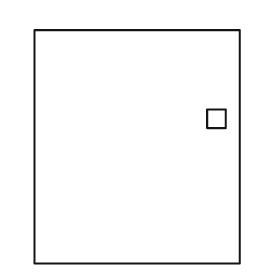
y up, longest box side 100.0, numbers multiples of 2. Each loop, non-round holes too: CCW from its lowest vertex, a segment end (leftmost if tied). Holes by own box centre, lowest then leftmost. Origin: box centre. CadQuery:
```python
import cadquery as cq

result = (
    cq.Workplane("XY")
    .moveTo(-44.0, -50.0)
    .lineTo(44.0, -50.0)
    .lineTo(44.0, 50.0)
    .lineTo(-44.0, 50.0)
    .close()
    .moveTo(30.0, 8.0)
    .lineTo(38.0, 8.0)
    .lineTo(38.0, 16.0)
    .lineTo(30.0, 16.0)
    .close()
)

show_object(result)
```